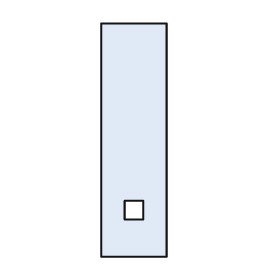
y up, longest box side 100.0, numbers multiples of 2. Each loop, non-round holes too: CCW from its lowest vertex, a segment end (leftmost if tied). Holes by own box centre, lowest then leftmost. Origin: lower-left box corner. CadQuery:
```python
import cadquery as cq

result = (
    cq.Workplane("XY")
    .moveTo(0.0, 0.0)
    .lineTo(28.0, 0.0)
    .lineTo(28.0, 100.0)
    .lineTo(0.0, 100.0)
    .close()
    .moveTo(10.0, 16.0)
    .lineTo(18.0, 16.0)
    .lineTo(18.0, 24.0)
    .lineTo(10.0, 24.0)
    .close()
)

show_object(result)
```